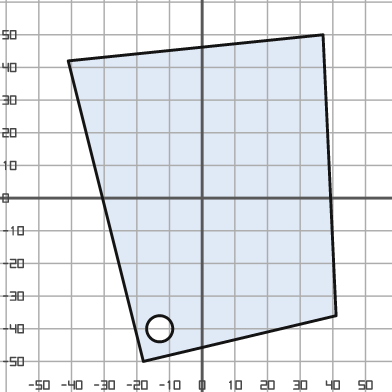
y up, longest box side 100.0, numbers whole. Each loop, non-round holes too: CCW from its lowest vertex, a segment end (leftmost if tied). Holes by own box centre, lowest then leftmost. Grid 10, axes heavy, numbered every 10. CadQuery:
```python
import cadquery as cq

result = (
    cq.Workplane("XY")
    .moveTo(-18.0, -50.0)
    .lineTo(41.0, -36.0)
    .lineTo(37.0, 50.0)
    .lineTo(-41.0, 42.0)
    .close()
    .moveTo(-13.0, -40.0)
    .circle(4.0)
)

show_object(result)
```